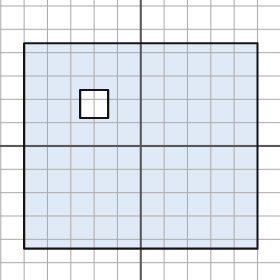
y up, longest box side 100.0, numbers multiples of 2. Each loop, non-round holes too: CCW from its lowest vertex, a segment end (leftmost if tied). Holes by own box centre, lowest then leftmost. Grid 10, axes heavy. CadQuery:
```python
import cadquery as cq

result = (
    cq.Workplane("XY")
    .moveTo(-50.0, -44.0)
    .lineTo(50.0, -44.0)
    .lineTo(50.0, 44.0)
    .lineTo(-50.0, 44.0)
    .close()
    .moveTo(-26.0, 12.0)
    .lineTo(-14.0, 12.0)
    .lineTo(-14.0, 24.0)
    .lineTo(-26.0, 24.0)
    .close()
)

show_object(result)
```